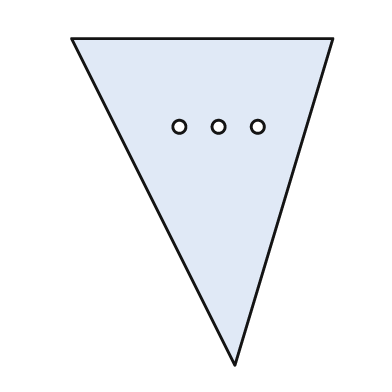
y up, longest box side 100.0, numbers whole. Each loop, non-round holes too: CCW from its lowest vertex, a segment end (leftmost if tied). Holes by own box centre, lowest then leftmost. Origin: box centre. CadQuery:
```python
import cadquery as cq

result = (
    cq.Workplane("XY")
    .moveTo(10.0, -50.0)
    .lineTo(40.0, 50.0)
    .lineTo(-40.0, 50.0)
    .close()
    .moveTo(-7.0, 23.0)
    .circle(2.0)
    .moveTo(5.0, 23.0)
    .circle(2.0)
    .moveTo(17.0, 23.0)
    .circle(2.0)
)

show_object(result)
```